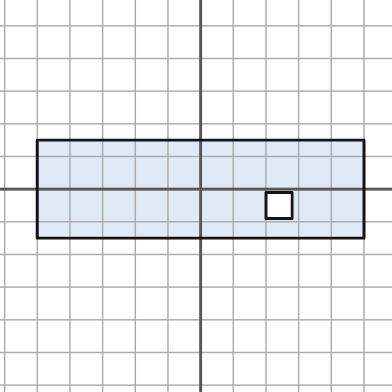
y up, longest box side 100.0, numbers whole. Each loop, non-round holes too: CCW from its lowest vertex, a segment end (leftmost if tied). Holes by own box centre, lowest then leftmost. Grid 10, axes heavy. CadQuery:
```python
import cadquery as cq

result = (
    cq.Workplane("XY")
    .moveTo(-50.0, -15.0)
    .lineTo(50.0, -15.0)
    .lineTo(50.0, 15.0)
    .lineTo(-50.0, 15.0)
    .close()
    .moveTo(20.0, -9.0)
    .lineTo(28.0, -9.0)
    .lineTo(28.0, -1.0)
    .lineTo(20.0, -1.0)
    .close()
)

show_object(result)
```